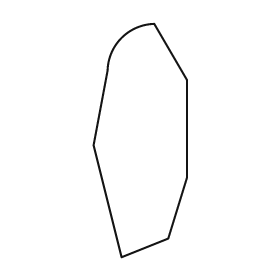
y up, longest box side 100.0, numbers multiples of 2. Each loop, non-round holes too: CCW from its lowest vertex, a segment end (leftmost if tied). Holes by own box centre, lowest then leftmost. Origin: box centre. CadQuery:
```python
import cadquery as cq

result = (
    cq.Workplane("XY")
    .moveTo(-8.0, -50.0)
    .lineTo(12.0, -42.0)
    .lineTo(20.0, -16.0)
    .lineTo(20.0, 26.0)
    .lineTo(6.0, 50.0)
    .threePointArc((-8.0, 44.0), (-14.0, 30.0))
    .lineTo(-20.0, -2.0)
    .close()
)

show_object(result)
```